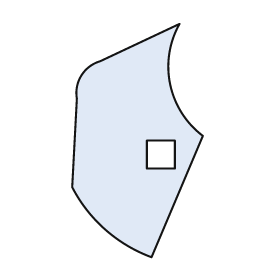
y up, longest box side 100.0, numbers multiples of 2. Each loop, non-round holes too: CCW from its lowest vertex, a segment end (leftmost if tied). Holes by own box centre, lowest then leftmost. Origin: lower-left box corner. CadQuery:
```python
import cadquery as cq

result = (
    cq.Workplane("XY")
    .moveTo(34.0, 0.0)
    .lineTo(56.0, 52.0)
    .threePointArc((42.0, 74.0), (46.0, 100.0))
    .lineTo(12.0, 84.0)
    .threePointArc((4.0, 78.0), (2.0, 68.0))
    .lineTo(0.0, 30.0)
    .threePointArc((14.0, 12.0), (34.0, 0.0))
    .close()
    .moveTo(32.0, 38.0)
    .lineTo(44.0, 38.0)
    .lineTo(44.0, 50.0)
    .lineTo(32.0, 50.0)
    .close()
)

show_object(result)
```